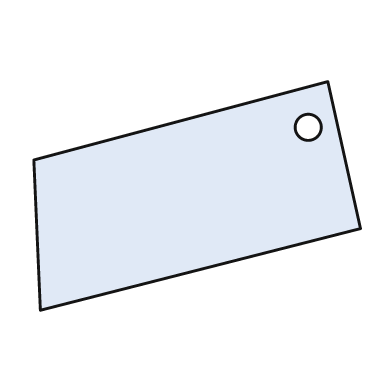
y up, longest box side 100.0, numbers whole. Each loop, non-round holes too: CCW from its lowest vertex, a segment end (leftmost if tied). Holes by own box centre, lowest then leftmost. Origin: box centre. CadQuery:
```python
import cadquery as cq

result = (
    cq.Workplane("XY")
    .moveTo(-48.0, -35.0)
    .lineTo(50.0, -10.0)
    .lineTo(40.0, 35.0)
    .lineTo(-50.0, 11.0)
    .close()
    .moveTo(34.0, 21.0)
    .circle(4.0)
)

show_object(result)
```